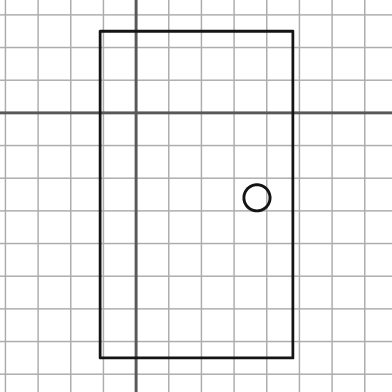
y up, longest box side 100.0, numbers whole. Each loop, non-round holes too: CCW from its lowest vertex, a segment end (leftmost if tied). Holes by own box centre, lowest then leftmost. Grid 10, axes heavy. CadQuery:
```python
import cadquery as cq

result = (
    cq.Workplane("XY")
    .moveTo(-11.0, -75.0)
    .lineTo(48.0, -75.0)
    .lineTo(48.0, 25.0)
    .lineTo(-11.0, 25.0)
    .close()
    .moveTo(37.0, -26.0)
    .circle(4.0)
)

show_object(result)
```